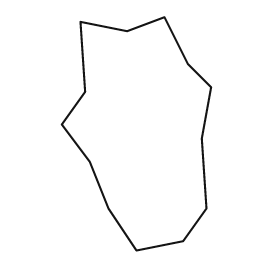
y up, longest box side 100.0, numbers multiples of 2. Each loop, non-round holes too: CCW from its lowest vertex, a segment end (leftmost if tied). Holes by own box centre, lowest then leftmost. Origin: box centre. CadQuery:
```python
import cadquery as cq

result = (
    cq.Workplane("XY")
    .moveTo(0.0, -50.0)
    .lineTo(20.0, -46.0)
    .lineTo(30.0, -32.0)
    .lineTo(28.0, -2.0)
    .lineTo(32.0, 20.0)
    .lineTo(22.0, 30.0)
    .lineTo(12.0, 50.0)
    .lineTo(-4.0, 44.0)
    .lineTo(-24.0, 48.0)
    .lineTo(-22.0, 18.0)
    .lineTo(-32.0, 4.0)
    .lineTo(-20.0, -12.0)
    .lineTo(-12.0, -32.0)
    .close()
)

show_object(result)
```